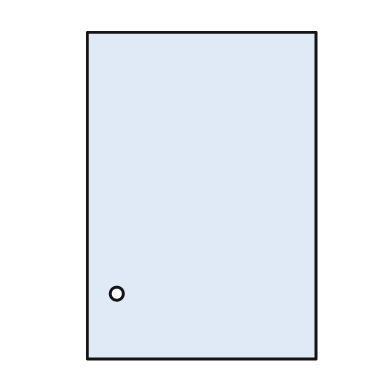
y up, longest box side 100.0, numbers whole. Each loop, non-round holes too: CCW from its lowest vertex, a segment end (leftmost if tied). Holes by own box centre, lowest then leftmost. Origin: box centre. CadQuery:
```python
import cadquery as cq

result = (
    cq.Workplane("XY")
    .moveTo(-35.0, -50.0)
    .lineTo(35.0, -50.0)
    .lineTo(35.0, 50.0)
    .lineTo(-35.0, 50.0)
    .close()
    .moveTo(-26.0, -30.0)
    .circle(2.0)
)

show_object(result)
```